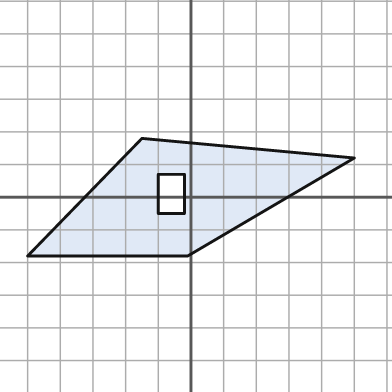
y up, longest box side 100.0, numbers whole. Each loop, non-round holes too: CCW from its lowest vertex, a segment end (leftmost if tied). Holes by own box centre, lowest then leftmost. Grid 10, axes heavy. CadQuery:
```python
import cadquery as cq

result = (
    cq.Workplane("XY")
    .moveTo(-50.0, -18.0)
    .lineTo(-1.0, -18.0)
    .lineTo(50.0, 12.0)
    .lineTo(-15.0, 18.0)
    .close()
    .moveTo(-10.0, -5.0)
    .lineTo(-2.0, -5.0)
    .lineTo(-2.0, 7.0)
    .lineTo(-10.0, 7.0)
    .close()
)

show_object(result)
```